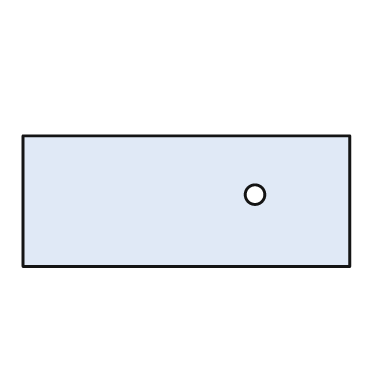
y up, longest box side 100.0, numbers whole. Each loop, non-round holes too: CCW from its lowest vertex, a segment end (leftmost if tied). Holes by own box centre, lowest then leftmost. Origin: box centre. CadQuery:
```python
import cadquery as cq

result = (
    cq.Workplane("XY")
    .moveTo(-50.0, -20.0)
    .lineTo(50.0, -20.0)
    .lineTo(50.0, 20.0)
    .lineTo(-50.0, 20.0)
    .close()
    .moveTo(21.0, 2.0)
    .circle(3.0)
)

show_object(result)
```